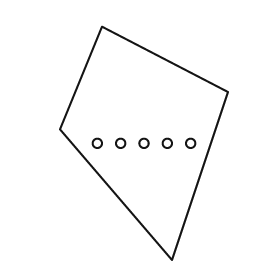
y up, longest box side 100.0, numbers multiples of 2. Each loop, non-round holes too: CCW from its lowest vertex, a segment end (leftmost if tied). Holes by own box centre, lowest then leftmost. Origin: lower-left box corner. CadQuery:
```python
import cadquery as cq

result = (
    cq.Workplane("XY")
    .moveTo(48.0, 0.0)
    .lineTo(72.0, 72.0)
    .lineTo(18.0, 100.0)
    .lineTo(0.0, 56.0)
    .close()
    .moveTo(16.0, 50.0)
    .circle(2.0)
    .moveTo(26.0, 50.0)
    .circle(2.0)
    .moveTo(36.0, 50.0)
    .circle(2.0)
    .moveTo(46.0, 50.0)
    .circle(2.0)
    .moveTo(56.0, 50.0)
    .circle(2.0)
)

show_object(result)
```